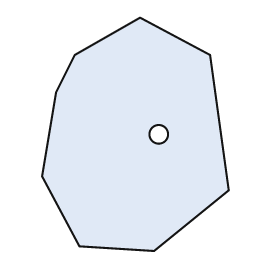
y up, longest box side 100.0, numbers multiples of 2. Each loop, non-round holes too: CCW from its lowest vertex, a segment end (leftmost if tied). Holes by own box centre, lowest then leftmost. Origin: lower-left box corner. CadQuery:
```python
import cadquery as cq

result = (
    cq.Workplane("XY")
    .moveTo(48.0, 0.0)
    .lineTo(80.0, 26.0)
    .lineTo(72.0, 84.0)
    .lineTo(42.0, 100.0)
    .lineTo(14.0, 84.0)
    .lineTo(6.0, 68.0)
    .lineTo(0.0, 32.0)
    .lineTo(16.0, 2.0)
    .close()
    .moveTo(50.0, 50.0)
    .circle(4.0)
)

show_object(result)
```